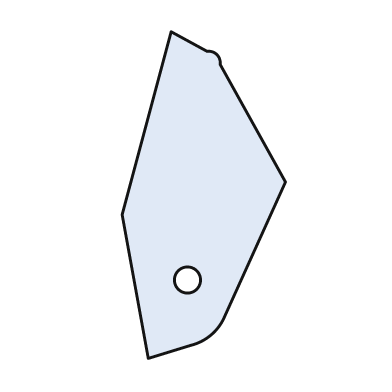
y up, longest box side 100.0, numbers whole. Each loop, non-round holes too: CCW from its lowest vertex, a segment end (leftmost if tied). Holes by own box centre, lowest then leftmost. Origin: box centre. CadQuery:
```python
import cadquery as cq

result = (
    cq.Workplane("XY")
    .moveTo(-17.0, -50.0)
    .lineTo(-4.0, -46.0)
    .threePointArc((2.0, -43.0), (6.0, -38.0))
    .lineTo(25.0, 4.0)
    .lineTo(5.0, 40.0)
    .threePointArc((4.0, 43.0), (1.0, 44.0))
    .lineTo(-10.0, 50.0)
    .lineTo(-25.0, -6.0)
    .close()
    .moveTo(-5.0, -26.0)
    .circle(4.0)
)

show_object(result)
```